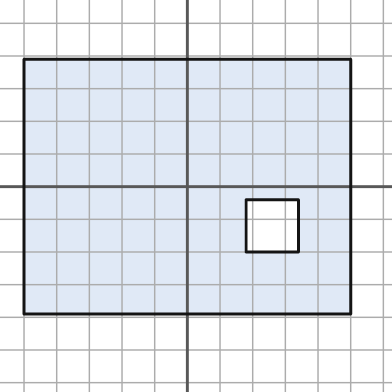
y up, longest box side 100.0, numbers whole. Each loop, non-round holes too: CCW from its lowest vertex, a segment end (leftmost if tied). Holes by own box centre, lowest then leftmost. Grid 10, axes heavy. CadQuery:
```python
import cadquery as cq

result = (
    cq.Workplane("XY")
    .moveTo(-50.0, -39.0)
    .lineTo(50.0, -39.0)
    .lineTo(50.0, 39.0)
    .lineTo(-50.0, 39.0)
    .close()
    .moveTo(18.0, -20.0)
    .lineTo(34.0, -20.0)
    .lineTo(34.0, -4.0)
    .lineTo(18.0, -4.0)
    .close()
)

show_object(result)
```